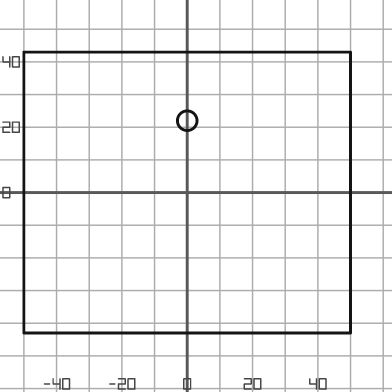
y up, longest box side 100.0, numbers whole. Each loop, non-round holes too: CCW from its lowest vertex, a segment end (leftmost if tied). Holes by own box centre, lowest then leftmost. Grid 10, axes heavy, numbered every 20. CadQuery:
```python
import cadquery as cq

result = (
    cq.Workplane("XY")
    .moveTo(-50.0, -43.0)
    .lineTo(50.0, -43.0)
    .lineTo(50.0, 43.0)
    .lineTo(-50.0, 43.0)
    .close()
    .moveTo(0.0, 22.0)
    .circle(3.0)
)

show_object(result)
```